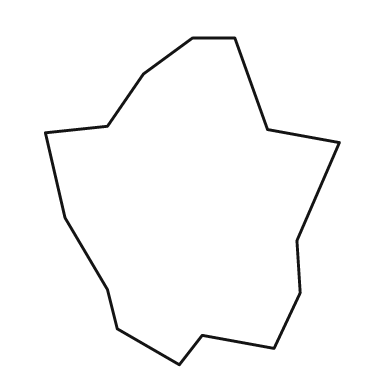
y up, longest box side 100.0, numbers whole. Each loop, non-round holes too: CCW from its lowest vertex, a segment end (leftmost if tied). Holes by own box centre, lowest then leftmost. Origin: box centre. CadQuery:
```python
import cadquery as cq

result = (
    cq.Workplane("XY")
    .moveTo(-4.0, -50.0)
    .lineTo(3.0, -41.0)
    .lineTo(25.0, -45.0)
    .lineTo(33.0, -28.0)
    .lineTo(32.0, -12.0)
    .lineTo(45.0, 18.0)
    .lineTo(23.0, 22.0)
    .lineTo(13.0, 50.0)
    .lineTo(0.0, 50.0)
    .lineTo(-15.0, 39.0)
    .lineTo(-26.0, 23.0)
    .lineTo(-45.0, 21.0)
    .lineTo(-39.0, -5.0)
    .lineTo(-26.0, -27.0)
    .lineTo(-23.0, -39.0)
    .close()
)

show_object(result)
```